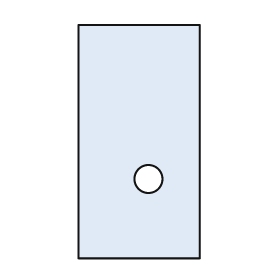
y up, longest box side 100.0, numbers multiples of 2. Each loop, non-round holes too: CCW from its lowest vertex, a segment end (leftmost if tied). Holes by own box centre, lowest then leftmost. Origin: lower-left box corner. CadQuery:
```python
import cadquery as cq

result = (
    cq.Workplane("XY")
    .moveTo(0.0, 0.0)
    .lineTo(52.0, 0.0)
    .lineTo(52.0, 100.0)
    .lineTo(0.0, 100.0)
    .close()
    .moveTo(30.0, 34.0)
    .circle(6.0)
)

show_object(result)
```